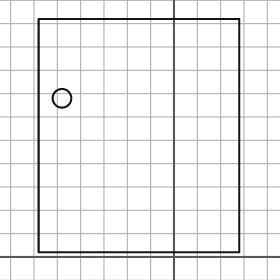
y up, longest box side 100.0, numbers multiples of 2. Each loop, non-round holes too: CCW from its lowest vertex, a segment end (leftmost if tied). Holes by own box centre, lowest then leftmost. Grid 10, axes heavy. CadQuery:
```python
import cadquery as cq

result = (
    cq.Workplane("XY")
    .moveTo(-58.0, 2.0)
    .lineTo(28.0, 2.0)
    .lineTo(28.0, 102.0)
    .lineTo(-58.0, 102.0)
    .close()
    .moveTo(-48.0, 68.0)
    .circle(4.0)
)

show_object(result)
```